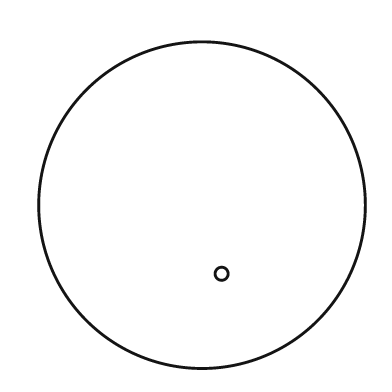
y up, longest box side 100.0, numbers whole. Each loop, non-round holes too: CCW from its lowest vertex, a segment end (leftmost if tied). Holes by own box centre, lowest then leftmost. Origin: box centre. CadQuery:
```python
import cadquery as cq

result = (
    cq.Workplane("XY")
    .moveTo(0.0, 0.0)
    .circle(50.0)
    .moveTo(6.0, -21.0)
    .circle(2.0)
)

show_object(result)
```